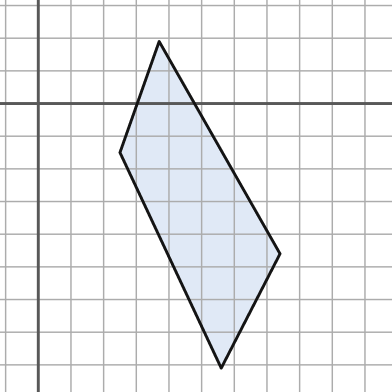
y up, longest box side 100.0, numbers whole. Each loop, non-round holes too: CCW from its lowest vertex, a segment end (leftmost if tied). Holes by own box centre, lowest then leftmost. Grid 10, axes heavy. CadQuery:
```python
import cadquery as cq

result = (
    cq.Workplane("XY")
    .moveTo(56.0, -81.0)
    .lineTo(74.0, -46.0)
    .lineTo(37.0, 19.0)
    .lineTo(25.0, -15.0)
    .close()
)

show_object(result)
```